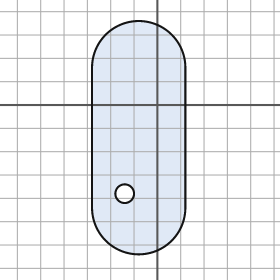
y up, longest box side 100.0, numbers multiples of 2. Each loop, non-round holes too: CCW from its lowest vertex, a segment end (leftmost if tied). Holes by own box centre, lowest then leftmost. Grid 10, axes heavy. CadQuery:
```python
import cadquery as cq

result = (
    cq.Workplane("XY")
    .moveTo(-28.0, -44.0)
    .threePointArc((-8.0, -64.0), (12.0, -44.0))
    .lineTo(12.0, 16.0)
    .threePointArc((-8.0, 36.0), (-28.0, 16.0))
    .close()
    .moveTo(-14.0, -38.0)
    .circle(4.0)
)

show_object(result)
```